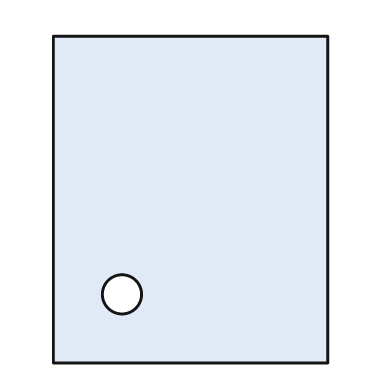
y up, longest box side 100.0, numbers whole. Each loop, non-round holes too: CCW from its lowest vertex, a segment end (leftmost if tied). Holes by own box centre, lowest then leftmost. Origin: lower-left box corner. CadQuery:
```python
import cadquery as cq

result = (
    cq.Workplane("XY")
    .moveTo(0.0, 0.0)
    .lineTo(84.0, 0.0)
    .lineTo(84.0, 100.0)
    .lineTo(0.0, 100.0)
    .close()
    .moveTo(21.0, 21.0)
    .circle(6.0)
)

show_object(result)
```